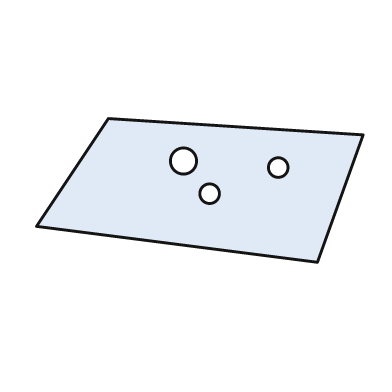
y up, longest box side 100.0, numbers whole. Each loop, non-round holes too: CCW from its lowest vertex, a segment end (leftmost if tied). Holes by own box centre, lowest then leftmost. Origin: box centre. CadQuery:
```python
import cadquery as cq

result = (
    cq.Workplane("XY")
    .moveTo(36.0, -22.0)
    .lineTo(50.0, 17.0)
    .lineTo(-28.0, 22.0)
    .lineTo(-50.0, -11.0)
    .close()
    .moveTo(3.0, -1.0)
    .circle(3.0)
    .moveTo(24.0, 7.0)
    .circle(3.0)
    .moveTo(-5.0, 9.0)
    .circle(4.0)
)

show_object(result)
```